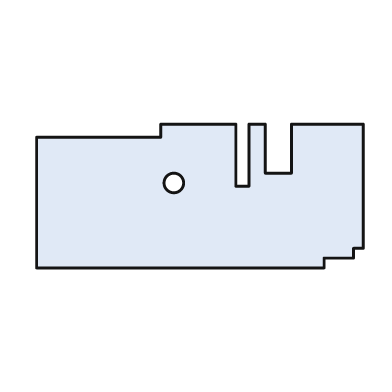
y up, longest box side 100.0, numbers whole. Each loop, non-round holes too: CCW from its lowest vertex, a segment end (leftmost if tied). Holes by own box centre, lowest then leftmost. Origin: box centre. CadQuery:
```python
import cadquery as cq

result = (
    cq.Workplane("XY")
    .moveTo(-50.0, -22.0)
    .lineTo(38.0, -22.0)
    .lineTo(38.0, -19.0)
    .lineTo(47.0, -19.0)
    .lineTo(47.0, -16.0)
    .lineTo(50.0, -16.0)
    .lineTo(50.0, 22.0)
    .lineTo(28.0, 22.0)
    .lineTo(28.0, 7.0)
    .lineTo(20.0, 7.0)
    .lineTo(20.0, 22.0)
    .lineTo(15.0, 22.0)
    .lineTo(15.0, 3.0)
    .lineTo(11.0, 3.0)
    .lineTo(11.0, 22.0)
    .lineTo(-12.0, 22.0)
    .lineTo(-12.0, 18.0)
    .lineTo(-50.0, 18.0)
    .close()
    .moveTo(-8.0, 4.0)
    .circle(3.0)
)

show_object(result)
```